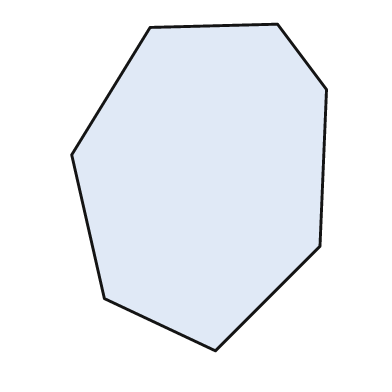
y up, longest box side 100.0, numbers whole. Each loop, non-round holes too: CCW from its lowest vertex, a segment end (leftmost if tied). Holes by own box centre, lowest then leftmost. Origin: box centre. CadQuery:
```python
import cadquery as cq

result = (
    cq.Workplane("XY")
    .moveTo(5.0, -50.0)
    .lineTo(37.0, -18.0)
    .lineTo(39.0, 30.0)
    .lineTo(24.0, 50.0)
    .lineTo(-15.0, 49.0)
    .lineTo(-39.0, 10.0)
    .lineTo(-29.0, -34.0)
    .close()
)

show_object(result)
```